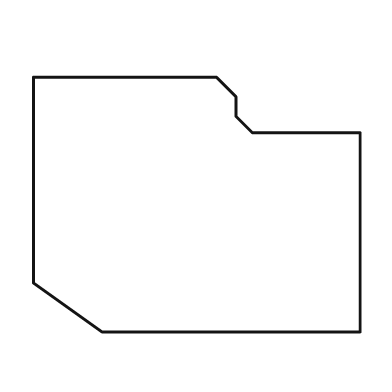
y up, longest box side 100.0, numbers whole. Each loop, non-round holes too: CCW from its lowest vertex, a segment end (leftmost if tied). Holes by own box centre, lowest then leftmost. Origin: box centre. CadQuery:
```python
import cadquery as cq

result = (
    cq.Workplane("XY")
    .moveTo(-29.0, -39.0)
    .lineTo(50.0, -39.0)
    .lineTo(50.0, 22.0)
    .lineTo(17.0, 22.0)
    .lineTo(12.0, 27.0)
    .lineTo(12.0, 33.0)
    .lineTo(6.0, 39.0)
    .lineTo(-50.0, 39.0)
    .lineTo(-50.0, -24.0)
    .close()
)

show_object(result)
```